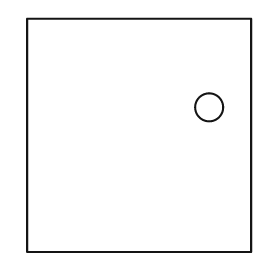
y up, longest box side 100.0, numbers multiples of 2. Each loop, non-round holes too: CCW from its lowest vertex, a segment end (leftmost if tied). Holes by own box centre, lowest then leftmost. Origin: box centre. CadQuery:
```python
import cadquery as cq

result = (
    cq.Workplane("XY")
    .moveTo(-48.0, -50.0)
    .lineTo(48.0, -50.0)
    .lineTo(48.0, 50.0)
    .lineTo(-48.0, 50.0)
    .close()
    .moveTo(30.0, 12.0)
    .circle(6.0)
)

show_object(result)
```